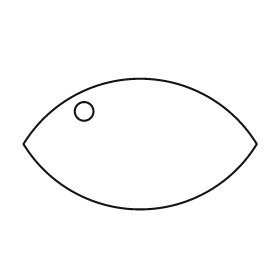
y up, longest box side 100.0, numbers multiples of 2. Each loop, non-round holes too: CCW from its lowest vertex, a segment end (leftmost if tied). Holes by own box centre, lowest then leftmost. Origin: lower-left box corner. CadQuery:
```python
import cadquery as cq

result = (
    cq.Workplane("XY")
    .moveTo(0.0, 28.0)
    .threePointArc((50.0, 0.0), (100.0, 28.0))
    .threePointArc((50.0, 56.0), (0.0, 28.0))
    .close()
    .moveTo(26.0, 42.0)
    .circle(4.0)
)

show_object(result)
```